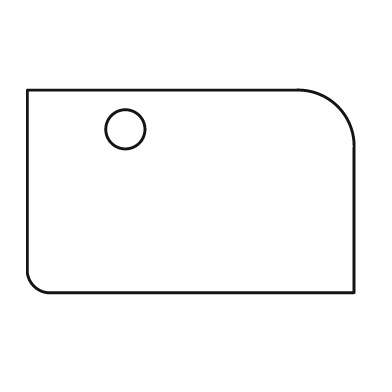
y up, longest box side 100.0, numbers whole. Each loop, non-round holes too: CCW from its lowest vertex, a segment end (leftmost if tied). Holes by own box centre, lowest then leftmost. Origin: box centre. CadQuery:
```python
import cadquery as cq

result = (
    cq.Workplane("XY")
    .moveTo(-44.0, -31.0)
    .lineTo(50.0, -31.0)
    .lineTo(50.0, 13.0)
    .threePointArc((45.0, 26.0), (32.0, 31.0))
    .lineTo(-50.0, 31.0)
    .lineTo(-50.0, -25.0)
    .threePointArc((-48.0, -29.0), (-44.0, -31.0))
    .close()
    .moveTo(-20.0, 19.0)
    .circle(6.0)
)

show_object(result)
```